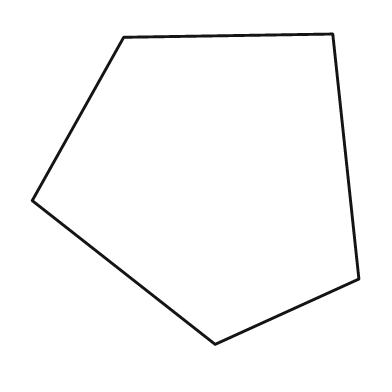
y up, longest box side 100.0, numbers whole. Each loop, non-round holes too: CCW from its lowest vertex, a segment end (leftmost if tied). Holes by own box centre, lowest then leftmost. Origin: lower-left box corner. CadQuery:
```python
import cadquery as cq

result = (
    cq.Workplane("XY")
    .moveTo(56.0, 0.0)
    .lineTo(100.0, 20.0)
    .lineTo(92.0, 95.0)
    .lineTo(28.0, 94.0)
    .lineTo(0.0, 44.0)
    .close()
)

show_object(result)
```